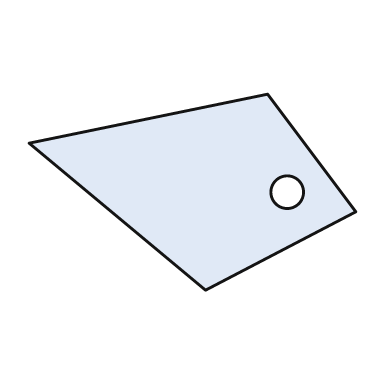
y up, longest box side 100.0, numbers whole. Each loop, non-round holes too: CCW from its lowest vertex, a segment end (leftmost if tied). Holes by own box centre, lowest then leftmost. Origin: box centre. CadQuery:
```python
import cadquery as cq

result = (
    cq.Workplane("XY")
    .moveTo(4.0, -30.0)
    .lineTo(50.0, -6.0)
    .lineTo(23.0, 30.0)
    .lineTo(-50.0, 15.0)
    .close()
    .moveTo(29.0, 0.0)
    .circle(5.0)
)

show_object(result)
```